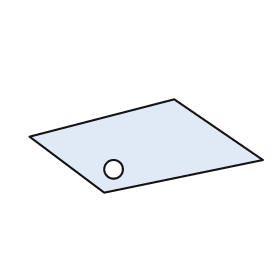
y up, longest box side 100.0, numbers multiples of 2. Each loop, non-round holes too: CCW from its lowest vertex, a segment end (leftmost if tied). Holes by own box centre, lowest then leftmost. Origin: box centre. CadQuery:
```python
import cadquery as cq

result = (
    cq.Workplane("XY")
    .moveTo(-18.0, -20.0)
    .lineTo(50.0, -6.0)
    .lineTo(12.0, 20.0)
    .lineTo(-50.0, 4.0)
    .close()
    .moveTo(-14.0, -10.0)
    .circle(4.0)
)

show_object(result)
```